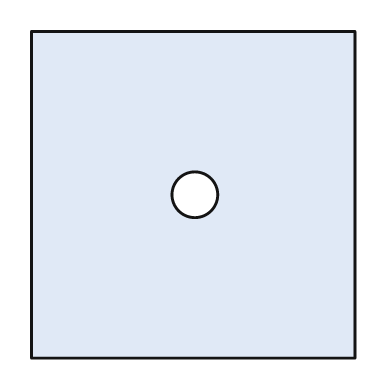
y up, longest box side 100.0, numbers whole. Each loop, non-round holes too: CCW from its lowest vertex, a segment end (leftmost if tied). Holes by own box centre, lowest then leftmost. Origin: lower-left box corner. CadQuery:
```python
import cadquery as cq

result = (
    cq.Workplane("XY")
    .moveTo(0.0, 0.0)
    .lineTo(99.0, 0.0)
    .lineTo(99.0, 100.0)
    .lineTo(0.0, 100.0)
    .close()
    .moveTo(50.0, 50.0)
    .circle(7.0)
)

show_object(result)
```